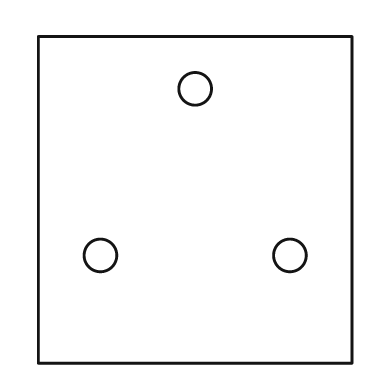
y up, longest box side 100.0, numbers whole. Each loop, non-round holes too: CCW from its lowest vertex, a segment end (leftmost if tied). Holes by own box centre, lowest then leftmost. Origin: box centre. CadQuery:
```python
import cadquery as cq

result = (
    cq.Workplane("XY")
    .moveTo(-48.0, -50.0)
    .lineTo(48.0, -50.0)
    .lineTo(48.0, 50.0)
    .lineTo(-48.0, 50.0)
    .close()
    .moveTo(-29.0, -17.0)
    .circle(5.0)
    .moveTo(29.0, -17.0)
    .circle(5.0)
    .moveTo(0.0, 34.0)
    .circle(5.0)
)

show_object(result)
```